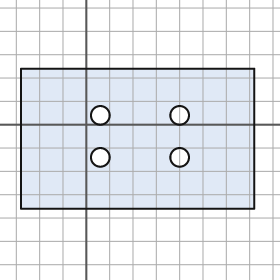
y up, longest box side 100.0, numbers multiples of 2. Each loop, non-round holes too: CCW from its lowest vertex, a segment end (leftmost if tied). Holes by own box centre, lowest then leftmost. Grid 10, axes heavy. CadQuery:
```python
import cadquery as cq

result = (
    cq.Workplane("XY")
    .moveTo(-28.0, -36.0)
    .lineTo(72.0, -36.0)
    .lineTo(72.0, 24.0)
    .lineTo(-28.0, 24.0)
    .close()
    .moveTo(6.0, -14.0)
    .circle(4.0)
    .moveTo(40.0, -14.0)
    .circle(4.0)
    .moveTo(6.0, 4.0)
    .circle(4.0)
    .moveTo(40.0, 4.0)
    .circle(4.0)
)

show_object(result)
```